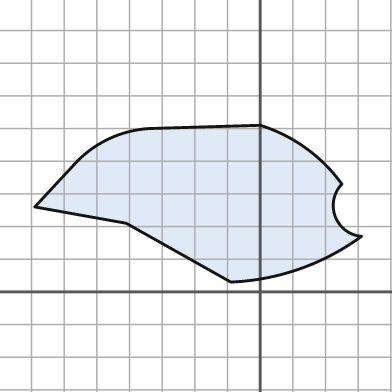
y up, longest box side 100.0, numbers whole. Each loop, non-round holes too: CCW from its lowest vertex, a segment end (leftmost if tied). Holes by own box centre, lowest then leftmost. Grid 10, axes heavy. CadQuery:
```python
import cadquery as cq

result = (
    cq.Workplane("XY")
    .moveTo(-9.0, 3.0)
    .threePointArc((12.0, 7.0), (31.0, 17.0))
    .threePointArc((23.0, 23.0), (25.0, 33.0))
    .threePointArc((14.0, 44.0), (0.0, 51.0))
    .lineTo(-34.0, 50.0)
    .threePointArc((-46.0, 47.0), (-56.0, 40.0))
    .lineTo(-69.0, 26.0)
    .lineTo(-41.0, 21.0)
    .close()
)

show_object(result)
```